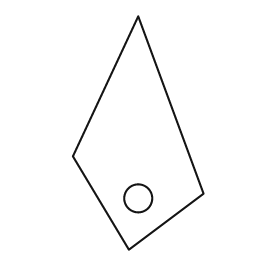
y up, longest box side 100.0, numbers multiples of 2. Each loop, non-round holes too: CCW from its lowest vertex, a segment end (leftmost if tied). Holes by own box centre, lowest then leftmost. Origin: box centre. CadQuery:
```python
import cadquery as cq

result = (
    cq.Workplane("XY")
    .moveTo(-4.0, -50.0)
    .lineTo(28.0, -26.0)
    .lineTo(0.0, 50.0)
    .lineTo(-28.0, -10.0)
    .close()
    .moveTo(0.0, -28.0)
    .circle(6.0)
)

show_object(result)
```